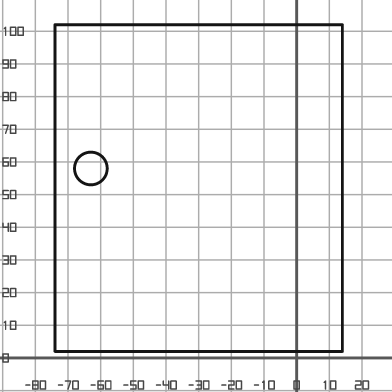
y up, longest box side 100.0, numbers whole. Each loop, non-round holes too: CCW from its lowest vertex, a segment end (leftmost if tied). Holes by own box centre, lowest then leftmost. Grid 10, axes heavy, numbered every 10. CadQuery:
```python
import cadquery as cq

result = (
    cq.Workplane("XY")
    .moveTo(-74.0, 2.0)
    .lineTo(14.0, 2.0)
    .lineTo(14.0, 102.0)
    .lineTo(-74.0, 102.0)
    .close()
    .moveTo(-63.0, 58.0)
    .circle(5.0)
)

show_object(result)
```